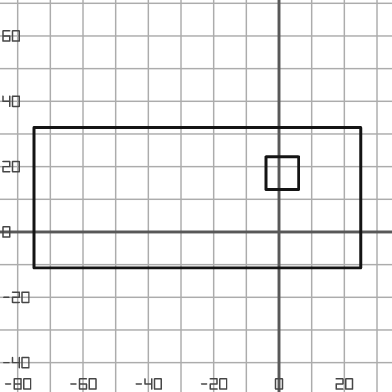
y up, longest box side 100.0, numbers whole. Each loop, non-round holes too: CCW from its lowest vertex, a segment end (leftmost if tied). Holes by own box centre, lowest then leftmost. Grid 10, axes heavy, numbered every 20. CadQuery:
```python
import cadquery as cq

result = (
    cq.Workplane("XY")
    .moveTo(-75.0, -11.0)
    .lineTo(25.0, -11.0)
    .lineTo(25.0, 32.0)
    .lineTo(-75.0, 32.0)
    .close()
    .moveTo(-4.0, 13.0)
    .lineTo(6.0, 13.0)
    .lineTo(6.0, 23.0)
    .lineTo(-4.0, 23.0)
    .close()
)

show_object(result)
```